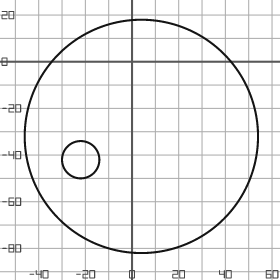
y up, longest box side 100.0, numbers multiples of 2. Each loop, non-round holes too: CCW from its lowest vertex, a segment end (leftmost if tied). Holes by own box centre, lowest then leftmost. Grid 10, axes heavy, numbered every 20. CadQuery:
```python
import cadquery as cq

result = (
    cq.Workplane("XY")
    .moveTo(4.0, -32.0)
    .circle(50.0)
    .moveTo(-22.0, -42.0)
    .circle(8.0)
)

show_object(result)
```